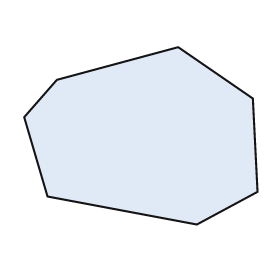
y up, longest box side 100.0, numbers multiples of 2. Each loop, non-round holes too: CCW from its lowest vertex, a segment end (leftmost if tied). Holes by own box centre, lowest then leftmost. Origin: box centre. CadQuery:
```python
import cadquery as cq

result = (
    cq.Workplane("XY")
    .moveTo(24.0, -38.0)
    .lineTo(50.0, -24.0)
    .lineTo(48.0, 16.0)
    .lineTo(16.0, 38.0)
    .lineTo(-36.0, 24.0)
    .lineTo(-50.0, 8.0)
    .lineTo(-40.0, -26.0)
    .close()
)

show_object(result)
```